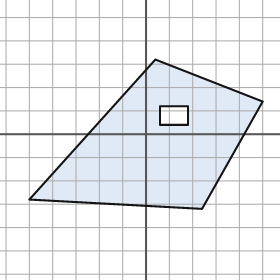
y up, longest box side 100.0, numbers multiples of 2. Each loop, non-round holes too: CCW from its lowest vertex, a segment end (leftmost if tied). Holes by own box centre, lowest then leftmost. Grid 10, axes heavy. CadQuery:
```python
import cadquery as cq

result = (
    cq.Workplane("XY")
    .moveTo(24.0, -32.0)
    .lineTo(50.0, 14.0)
    .lineTo(4.0, 32.0)
    .lineTo(-50.0, -28.0)
    .close()
    .moveTo(6.0, 4.0)
    .lineTo(18.0, 4.0)
    .lineTo(18.0, 12.0)
    .lineTo(6.0, 12.0)
    .close()
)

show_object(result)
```